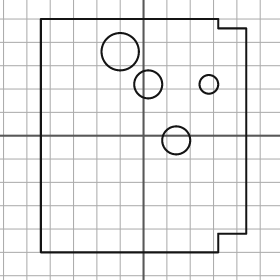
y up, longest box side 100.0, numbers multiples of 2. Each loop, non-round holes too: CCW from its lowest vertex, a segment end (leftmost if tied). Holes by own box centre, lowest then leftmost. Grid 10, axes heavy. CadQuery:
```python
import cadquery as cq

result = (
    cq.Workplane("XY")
    .moveTo(-44.0, -50.0)
    .lineTo(32.0, -50.0)
    .lineTo(32.0, -42.0)
    .lineTo(44.0, -42.0)
    .lineTo(44.0, 46.0)
    .lineTo(32.0, 46.0)
    .lineTo(32.0, 50.0)
    .lineTo(-44.0, 50.0)
    .close()
    .moveTo(14.0, -2.0)
    .circle(6.0)
    .moveTo(2.0, 22.0)
    .circle(6.0)
    .moveTo(28.0, 22.0)
    .circle(4.0)
    .moveTo(-10.0, 36.0)
    .circle(8.0)
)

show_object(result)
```